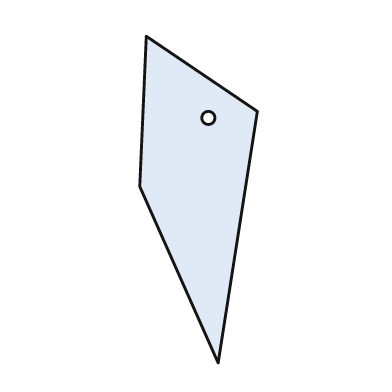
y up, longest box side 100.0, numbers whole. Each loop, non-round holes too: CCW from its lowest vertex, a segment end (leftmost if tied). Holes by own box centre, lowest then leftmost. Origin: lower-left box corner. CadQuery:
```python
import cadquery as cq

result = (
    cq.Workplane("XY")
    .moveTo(24.0, 0.0)
    .lineTo(36.0, 77.0)
    .lineTo(2.0, 100.0)
    .lineTo(0.0, 54.0)
    .close()
    .moveTo(21.0, 75.0)
    .circle(2.0)
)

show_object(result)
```